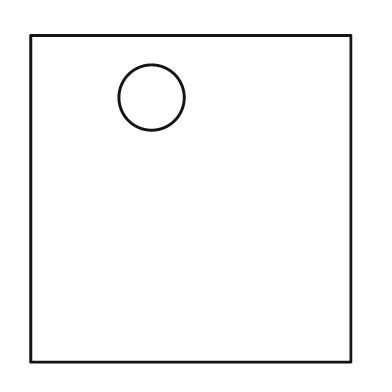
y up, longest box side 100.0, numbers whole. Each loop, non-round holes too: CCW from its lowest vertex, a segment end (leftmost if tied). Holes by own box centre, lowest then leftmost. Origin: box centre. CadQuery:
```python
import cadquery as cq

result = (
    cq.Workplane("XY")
    .moveTo(-49.0, -50.0)
    .lineTo(49.0, -50.0)
    .lineTo(49.0, 50.0)
    .lineTo(-49.0, 50.0)
    .close()
    .moveTo(-12.0, 31.0)
    .circle(10.0)
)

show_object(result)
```